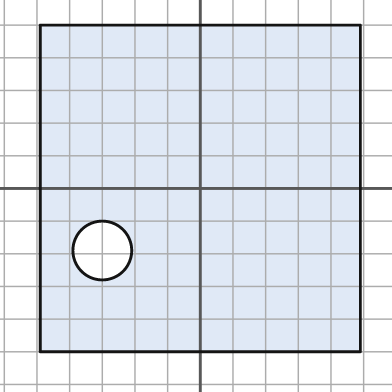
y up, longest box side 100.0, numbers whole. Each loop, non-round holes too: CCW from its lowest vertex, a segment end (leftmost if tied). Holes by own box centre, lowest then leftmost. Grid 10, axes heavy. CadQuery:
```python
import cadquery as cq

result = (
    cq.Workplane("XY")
    .moveTo(-49.0, -50.0)
    .lineTo(49.0, -50.0)
    .lineTo(49.0, 50.0)
    .lineTo(-49.0, 50.0)
    .close()
    .moveTo(-30.0, -19.0)
    .circle(9.0)
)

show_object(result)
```